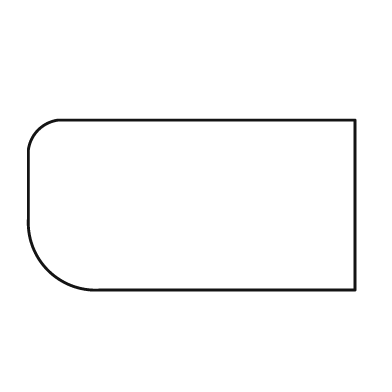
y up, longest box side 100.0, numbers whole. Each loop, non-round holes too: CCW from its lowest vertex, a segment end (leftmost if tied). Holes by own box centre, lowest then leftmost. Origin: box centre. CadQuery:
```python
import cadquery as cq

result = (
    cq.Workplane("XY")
    .moveTo(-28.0, -26.0)
    .lineTo(50.0, -26.0)
    .lineTo(50.0, 26.0)
    .lineTo(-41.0, 26.0)
    .threePointArc((-47.0, 23.0), (-50.0, 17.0))
    .lineTo(-50.0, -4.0)
    .threePointArc((-44.0, -20.0), (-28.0, -26.0))
    .close()
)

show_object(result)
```